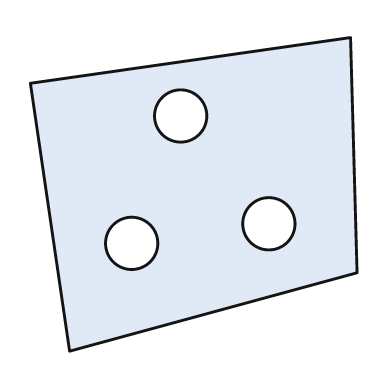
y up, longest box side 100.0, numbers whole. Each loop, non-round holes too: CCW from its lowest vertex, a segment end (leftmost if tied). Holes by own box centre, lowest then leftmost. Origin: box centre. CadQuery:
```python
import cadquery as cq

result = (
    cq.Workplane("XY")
    .moveTo(-38.0, -48.0)
    .lineTo(50.0, -24.0)
    .lineTo(48.0, 48.0)
    .lineTo(-50.0, 34.0)
    .close()
    .moveTo(-19.0, -15.0)
    .circle(8.0)
    .moveTo(23.0, -9.0)
    .circle(8.0)
    .moveTo(-4.0, 24.0)
    .circle(8.0)
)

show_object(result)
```